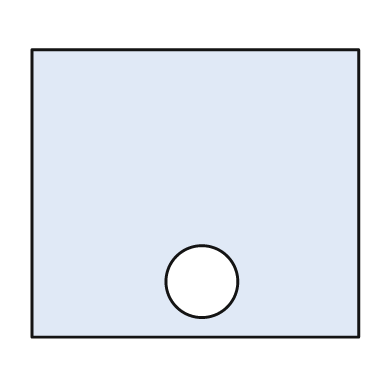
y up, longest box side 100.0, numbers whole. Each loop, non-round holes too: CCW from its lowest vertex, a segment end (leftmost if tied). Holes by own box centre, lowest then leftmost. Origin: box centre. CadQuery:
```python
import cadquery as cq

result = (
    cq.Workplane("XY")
    .moveTo(-50.0, -44.0)
    .lineTo(50.0, -44.0)
    .lineTo(50.0, 44.0)
    .lineTo(-50.0, 44.0)
    .close()
    .moveTo(2.0, -27.0)
    .circle(11.0)
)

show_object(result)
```